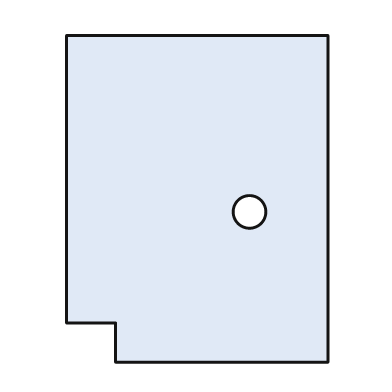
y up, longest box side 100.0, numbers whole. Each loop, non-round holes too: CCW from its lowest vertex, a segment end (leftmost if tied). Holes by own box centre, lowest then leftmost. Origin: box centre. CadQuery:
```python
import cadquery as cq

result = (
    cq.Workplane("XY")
    .moveTo(-25.0, -50.0)
    .lineTo(40.0, -50.0)
    .lineTo(40.0, 50.0)
    .lineTo(-40.0, 50.0)
    .lineTo(-40.0, -38.0)
    .lineTo(-25.0, -38.0)
    .close()
    .moveTo(16.0, -4.0)
    .circle(5.0)
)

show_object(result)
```